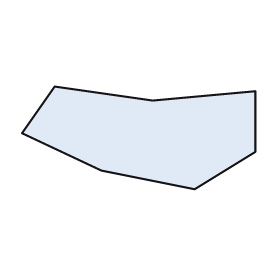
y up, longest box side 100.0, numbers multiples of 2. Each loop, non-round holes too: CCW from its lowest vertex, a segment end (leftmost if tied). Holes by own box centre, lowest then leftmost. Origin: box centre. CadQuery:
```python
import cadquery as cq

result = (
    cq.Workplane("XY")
    .moveTo(24.0, -22.0)
    .lineTo(50.0, -6.0)
    .lineTo(50.0, 20.0)
    .lineTo(6.0, 16.0)
    .lineTo(-36.0, 22.0)
    .lineTo(-50.0, 2.0)
    .lineTo(-16.0, -14.0)
    .close()
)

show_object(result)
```